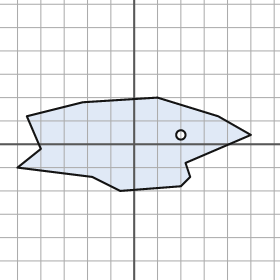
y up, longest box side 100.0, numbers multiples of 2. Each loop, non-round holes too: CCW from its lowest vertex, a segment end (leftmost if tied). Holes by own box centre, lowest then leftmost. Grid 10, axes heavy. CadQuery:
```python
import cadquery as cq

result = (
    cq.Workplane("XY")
    .moveTo(-6.0, -20.0)
    .lineTo(20.0, -18.0)
    .lineTo(24.0, -14.0)
    .lineTo(22.0, -8.0)
    .lineTo(50.0, 4.0)
    .lineTo(36.0, 12.0)
    .lineTo(10.0, 20.0)
    .lineTo(-22.0, 18.0)
    .lineTo(-46.0, 12.0)
    .lineTo(-40.0, -2.0)
    .lineTo(-50.0, -10.0)
    .lineTo(-18.0, -14.0)
    .close()
    .moveTo(20.0, 4.0)
    .circle(2.0)
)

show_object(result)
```